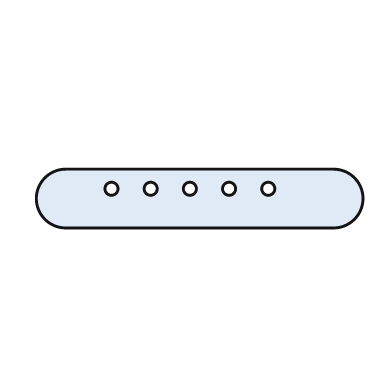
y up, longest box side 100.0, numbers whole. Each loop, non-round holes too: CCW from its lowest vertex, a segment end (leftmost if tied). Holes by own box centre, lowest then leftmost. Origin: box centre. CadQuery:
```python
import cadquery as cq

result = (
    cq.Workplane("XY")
    .moveTo(-41.0, -9.0)
    .lineTo(41.0, -9.0)
    .threePointArc((50.0, 0.0), (41.0, 9.0))
    .lineTo(-41.0, 9.0)
    .threePointArc((-50.0, 0.0), (-41.0, -9.0))
    .close()
    .moveTo(-27.0, 3.0)
    .circle(2.0)
    .moveTo(-15.0, 3.0)
    .circle(2.0)
    .moveTo(-3.0, 3.0)
    .circle(2.0)
    .moveTo(9.0, 3.0)
    .circle(2.0)
    .moveTo(21.0, 3.0)
    .circle(2.0)
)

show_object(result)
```